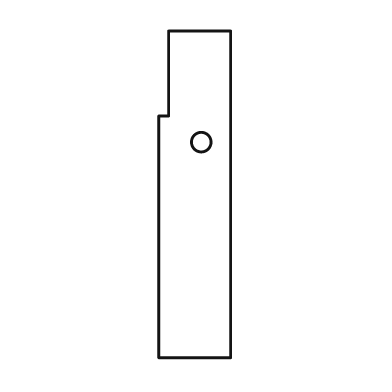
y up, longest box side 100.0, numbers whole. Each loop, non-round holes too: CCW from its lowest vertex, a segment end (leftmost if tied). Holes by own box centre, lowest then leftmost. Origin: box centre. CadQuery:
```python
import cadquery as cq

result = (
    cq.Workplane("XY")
    .moveTo(-11.0, -50.0)
    .lineTo(11.0, -50.0)
    .lineTo(11.0, 50.0)
    .lineTo(-8.0, 50.0)
    .lineTo(-8.0, 24.0)
    .lineTo(-11.0, 24.0)
    .close()
    .moveTo(2.0, 16.0)
    .circle(3.0)
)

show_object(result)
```